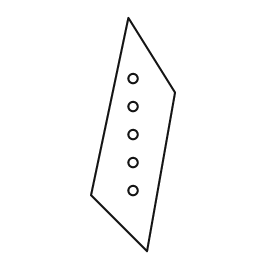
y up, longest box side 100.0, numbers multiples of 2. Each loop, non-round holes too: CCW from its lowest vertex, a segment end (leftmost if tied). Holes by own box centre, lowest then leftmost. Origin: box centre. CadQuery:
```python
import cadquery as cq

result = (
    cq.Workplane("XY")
    .moveTo(6.0, -50.0)
    .lineTo(18.0, 18.0)
    .lineTo(-2.0, 50.0)
    .lineTo(-18.0, -26.0)
    .close()
    .moveTo(0.0, -24.0)
    .circle(2.0)
    .moveTo(0.0, -12.0)
    .circle(2.0)
    .moveTo(0.0, 0.0)
    .circle(2.0)
    .moveTo(0.0, 12.0)
    .circle(2.0)
    .moveTo(0.0, 24.0)
    .circle(2.0)
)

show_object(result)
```